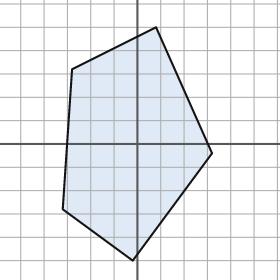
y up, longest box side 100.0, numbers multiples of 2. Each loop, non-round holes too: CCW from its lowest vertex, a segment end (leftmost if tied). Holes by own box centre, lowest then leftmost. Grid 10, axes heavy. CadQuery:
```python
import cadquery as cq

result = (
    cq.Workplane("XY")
    .moveTo(-2.0, -50.0)
    .lineTo(32.0, -4.0)
    .lineTo(8.0, 50.0)
    .lineTo(-28.0, 32.0)
    .lineTo(-32.0, -28.0)
    .close()
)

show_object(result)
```